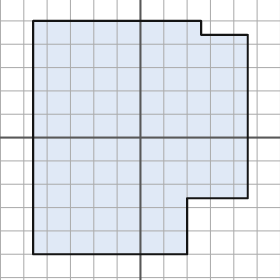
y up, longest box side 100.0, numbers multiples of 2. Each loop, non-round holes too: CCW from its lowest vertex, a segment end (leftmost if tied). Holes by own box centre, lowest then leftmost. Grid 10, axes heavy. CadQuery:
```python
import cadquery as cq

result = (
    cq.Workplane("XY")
    .moveTo(-46.0, -50.0)
    .lineTo(20.0, -50.0)
    .lineTo(20.0, -26.0)
    .lineTo(46.0, -26.0)
    .lineTo(46.0, 44.0)
    .lineTo(26.0, 44.0)
    .lineTo(26.0, 50.0)
    .lineTo(-46.0, 50.0)
    .close()
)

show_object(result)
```